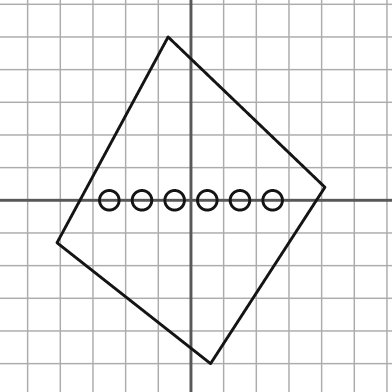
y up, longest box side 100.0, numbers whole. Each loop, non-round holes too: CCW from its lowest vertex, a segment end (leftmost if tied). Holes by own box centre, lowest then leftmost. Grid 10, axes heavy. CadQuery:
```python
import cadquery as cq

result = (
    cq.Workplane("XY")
    .moveTo(6.0, -50.0)
    .lineTo(41.0, 4.0)
    .lineTo(-7.0, 50.0)
    .lineTo(-41.0, -13.0)
    .close()
    .moveTo(-25.0, 0.0)
    .circle(3.0)
    .moveTo(-15.0, 0.0)
    .circle(3.0)
    .moveTo(-5.0, 0.0)
    .circle(3.0)
    .moveTo(5.0, 0.0)
    .circle(3.0)
    .moveTo(15.0, 0.0)
    .circle(3.0)
    .moveTo(25.0, 0.0)
    .circle(3.0)
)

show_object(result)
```